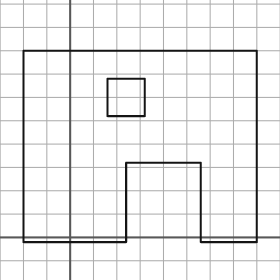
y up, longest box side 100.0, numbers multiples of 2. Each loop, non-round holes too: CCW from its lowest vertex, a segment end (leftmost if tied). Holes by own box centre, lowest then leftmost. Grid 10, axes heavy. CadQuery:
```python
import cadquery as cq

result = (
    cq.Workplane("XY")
    .moveTo(-20.0, -2.0)
    .lineTo(24.0, -2.0)
    .lineTo(24.0, 32.0)
    .lineTo(56.0, 32.0)
    .lineTo(56.0, -2.0)
    .lineTo(80.0, -2.0)
    .lineTo(80.0, 80.0)
    .lineTo(-20.0, 80.0)
    .close()
    .moveTo(16.0, 52.0)
    .lineTo(32.0, 52.0)
    .lineTo(32.0, 68.0)
    .lineTo(16.0, 68.0)
    .close()
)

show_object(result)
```